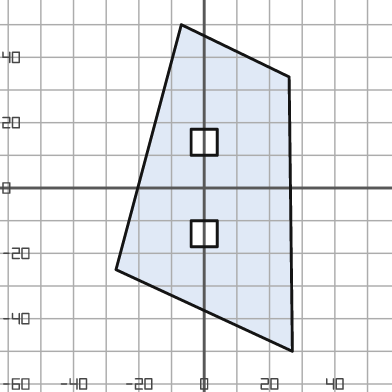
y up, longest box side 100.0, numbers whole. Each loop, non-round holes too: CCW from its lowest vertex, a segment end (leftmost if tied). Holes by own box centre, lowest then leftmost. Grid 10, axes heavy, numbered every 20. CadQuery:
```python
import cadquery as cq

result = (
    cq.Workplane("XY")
    .moveTo(27.0, -50.0)
    .lineTo(26.0, 34.0)
    .lineTo(-7.0, 50.0)
    .lineTo(-27.0, -25.0)
    .close()
    .moveTo(-4.0, -18.0)
    .lineTo(4.0, -18.0)
    .lineTo(4.0, -10.0)
    .lineTo(-4.0, -10.0)
    .close()
    .moveTo(-4.0, 10.0)
    .lineTo(4.0, 10.0)
    .lineTo(4.0, 18.0)
    .lineTo(-4.0, 18.0)
    .close()
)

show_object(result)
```